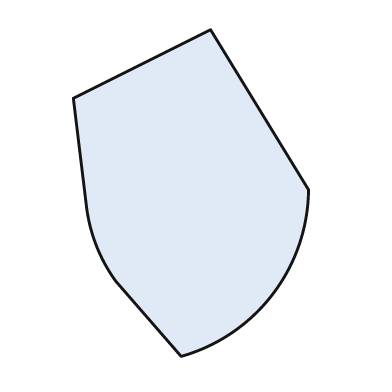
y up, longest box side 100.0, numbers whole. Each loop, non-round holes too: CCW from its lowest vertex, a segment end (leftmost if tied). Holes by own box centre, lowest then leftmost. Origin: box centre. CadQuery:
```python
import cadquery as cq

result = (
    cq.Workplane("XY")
    .moveTo(-3.0, -50.0)
    .threePointArc((25.0, -31.0), (36.0, 1.0))
    .lineTo(6.0, 50.0)
    .lineTo(-36.0, 29.0)
    .lineTo(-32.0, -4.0)
    .threePointArc((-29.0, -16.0), (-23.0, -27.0))
    .close()
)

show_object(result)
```